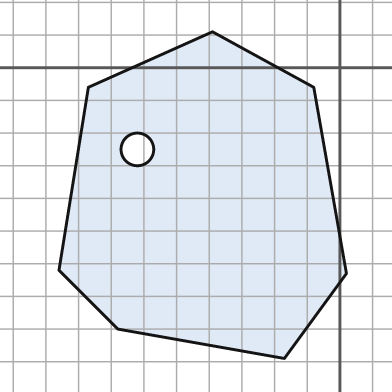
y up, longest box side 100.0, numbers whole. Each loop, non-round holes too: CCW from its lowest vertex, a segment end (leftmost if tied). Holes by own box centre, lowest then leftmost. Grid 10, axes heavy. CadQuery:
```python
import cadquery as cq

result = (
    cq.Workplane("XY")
    .moveTo(-17.0, -89.0)
    .lineTo(2.0, -63.0)
    .lineTo(-8.0, -6.0)
    .lineTo(-39.0, 11.0)
    .lineTo(-77.0, -6.0)
    .lineTo(-86.0, -62.0)
    .lineTo(-68.0, -80.0)
    .close()
    .moveTo(-62.0, -25.0)
    .circle(5.0)
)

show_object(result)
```